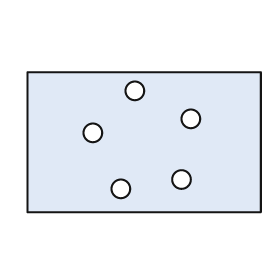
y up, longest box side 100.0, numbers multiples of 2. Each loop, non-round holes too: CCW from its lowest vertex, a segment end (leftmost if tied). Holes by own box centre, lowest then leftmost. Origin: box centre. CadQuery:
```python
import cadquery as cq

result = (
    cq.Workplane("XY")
    .moveTo(-50.0, -30.0)
    .lineTo(50.0, -30.0)
    .lineTo(50.0, 30.0)
    .lineTo(-50.0, 30.0)
    .close()
    .moveTo(-10.0, -20.0)
    .circle(4.0)
    .moveTo(16.0, -16.0)
    .circle(4.0)
    .moveTo(-22.0, 4.0)
    .circle(4.0)
    .moveTo(20.0, 10.0)
    .circle(4.0)
    .moveTo(-4.0, 22.0)
    .circle(4.0)
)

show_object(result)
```